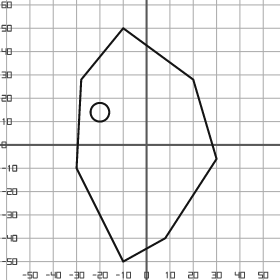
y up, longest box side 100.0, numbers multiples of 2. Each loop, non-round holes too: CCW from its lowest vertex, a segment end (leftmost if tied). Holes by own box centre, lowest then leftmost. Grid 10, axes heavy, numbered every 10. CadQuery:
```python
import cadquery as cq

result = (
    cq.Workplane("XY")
    .moveTo(-10.0, -50.0)
    .lineTo(8.0, -40.0)
    .lineTo(30.0, -6.0)
    .lineTo(20.0, 28.0)
    .lineTo(-10.0, 50.0)
    .lineTo(-28.0, 28.0)
    .lineTo(-30.0, -10.0)
    .close()
    .moveTo(-20.0, 14.0)
    .circle(4.0)
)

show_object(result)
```